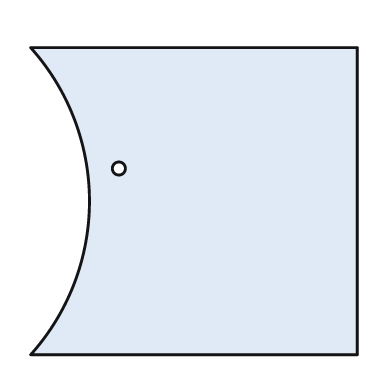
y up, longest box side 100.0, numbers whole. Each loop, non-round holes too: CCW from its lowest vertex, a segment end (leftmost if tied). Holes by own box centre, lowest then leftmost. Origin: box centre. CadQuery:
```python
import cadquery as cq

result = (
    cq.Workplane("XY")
    .moveTo(-50.0, -47.0)
    .lineTo(50.0, -47.0)
    .lineTo(50.0, 47.0)
    .lineTo(-50.0, 47.0)
    .threePointArc((-32.0, 0.0), (-50.0, -47.0))
    .close()
    .moveTo(-23.0, 10.0)
    .circle(2.0)
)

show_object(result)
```